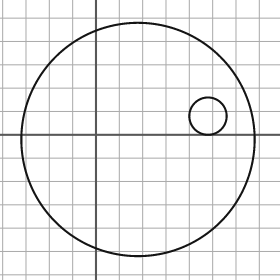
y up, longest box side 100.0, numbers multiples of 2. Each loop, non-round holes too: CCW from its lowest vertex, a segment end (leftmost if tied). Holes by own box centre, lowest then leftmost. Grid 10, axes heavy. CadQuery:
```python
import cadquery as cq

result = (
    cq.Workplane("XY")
    .moveTo(18.0, -2.0)
    .circle(50.0)
    .moveTo(48.0, 8.0)
    .circle(8.0)
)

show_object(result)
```